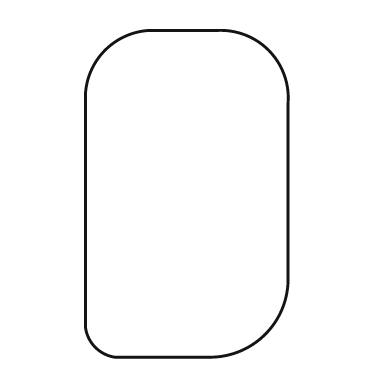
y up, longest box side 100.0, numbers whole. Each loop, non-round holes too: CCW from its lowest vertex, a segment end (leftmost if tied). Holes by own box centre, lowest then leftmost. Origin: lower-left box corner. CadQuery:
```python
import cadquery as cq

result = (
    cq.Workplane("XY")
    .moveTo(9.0, 0.0)
    .lineTo(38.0, 0.0)
    .threePointArc((55.0, 7.0), (62.0, 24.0))
    .lineTo(62.0, 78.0)
    .threePointArc((56.0, 94.0), (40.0, 100.0))
    .lineTo(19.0, 100.0)
    .threePointArc((6.0, 94.0), (0.0, 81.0))
    .lineTo(0.0, 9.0)
    .threePointArc((3.0, 3.0), (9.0, 0.0))
    .close()
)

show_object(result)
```